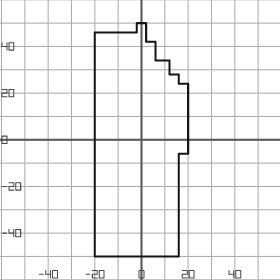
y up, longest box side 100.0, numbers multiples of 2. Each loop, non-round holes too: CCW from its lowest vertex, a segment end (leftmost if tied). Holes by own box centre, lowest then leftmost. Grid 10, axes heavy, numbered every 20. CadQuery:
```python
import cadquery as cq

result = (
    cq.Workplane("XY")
    .moveTo(-20.0, -50.0)
    .lineTo(16.0, -50.0)
    .lineTo(16.0, -6.0)
    .lineTo(20.0, -6.0)
    .lineTo(20.0, 24.0)
    .lineTo(16.0, 24.0)
    .lineTo(16.0, 28.0)
    .lineTo(12.0, 28.0)
    .lineTo(12.0, 34.0)
    .lineTo(6.0, 34.0)
    .lineTo(6.0, 42.0)
    .lineTo(2.0, 42.0)
    .lineTo(2.0, 50.0)
    .lineTo(-2.0, 50.0)
    .lineTo(-2.0, 46.0)
    .lineTo(-20.0, 46.0)
    .close()
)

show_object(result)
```